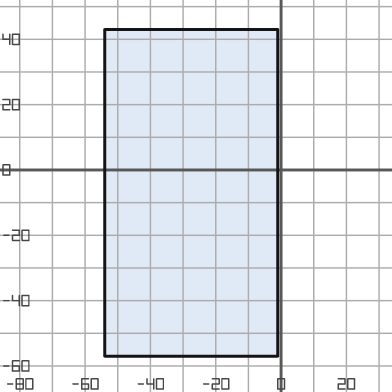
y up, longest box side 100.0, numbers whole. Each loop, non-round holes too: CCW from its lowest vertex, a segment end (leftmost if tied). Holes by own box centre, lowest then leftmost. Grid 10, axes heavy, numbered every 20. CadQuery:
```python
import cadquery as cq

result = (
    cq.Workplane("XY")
    .moveTo(-54.0, -57.0)
    .lineTo(-1.0, -57.0)
    .lineTo(-1.0, 43.0)
    .lineTo(-54.0, 43.0)
    .close()
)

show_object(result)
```